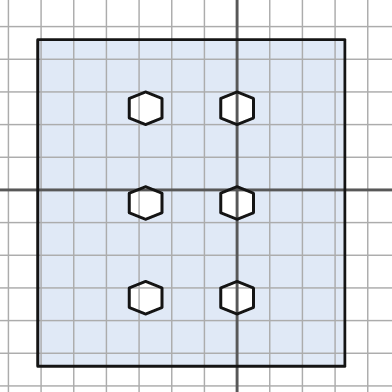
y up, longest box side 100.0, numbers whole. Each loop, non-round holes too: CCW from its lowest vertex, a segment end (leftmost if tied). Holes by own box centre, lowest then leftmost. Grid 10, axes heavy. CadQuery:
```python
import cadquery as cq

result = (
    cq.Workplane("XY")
    .moveTo(-61.0, -54.0)
    .lineTo(33.0, -54.0)
    .lineTo(33.0, 46.0)
    .lineTo(-61.0, 46.0)
    .close()
    .moveTo(-28.0, -38.0)
    .lineTo(-23.0, -36.0)
    .lineTo(-23.0, -30.0)
    .lineTo(-28.0, -28.0)
    .lineTo(-33.0, -30.0)
    .lineTo(-33.0, -36.0)
    .close()
    .moveTo(0.0, -38.0)
    .lineTo(5.0, -36.0)
    .lineTo(5.0, -30.0)
    .lineTo(0.0, -28.0)
    .lineTo(-5.0, -30.0)
    .lineTo(-5.0, -36.0)
    .close()
    .moveTo(-28.0, -9.0)
    .lineTo(-23.0, -7.0)
    .lineTo(-23.0, -1.0)
    .lineTo(-28.0, 1.0)
    .lineTo(-33.0, -1.0)
    .lineTo(-33.0, -7.0)
    .close()
    .moveTo(0.0, -9.0)
    .lineTo(5.0, -7.0)
    .lineTo(5.0, -1.0)
    .lineTo(0.0, 1.0)
    .lineTo(-5.0, -1.0)
    .lineTo(-5.0, -7.0)
    .close()
    .moveTo(-28.0, 20.0)
    .lineTo(-23.0, 22.0)
    .lineTo(-23.0, 28.0)
    .lineTo(-28.0, 30.0)
    .lineTo(-33.0, 28.0)
    .lineTo(-33.0, 22.0)
    .close()
    .moveTo(0.0, 20.0)
    .lineTo(5.0, 22.0)
    .lineTo(5.0, 28.0)
    .lineTo(0.0, 30.0)
    .lineTo(-5.0, 28.0)
    .lineTo(-5.0, 22.0)
    .close()
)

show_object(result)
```